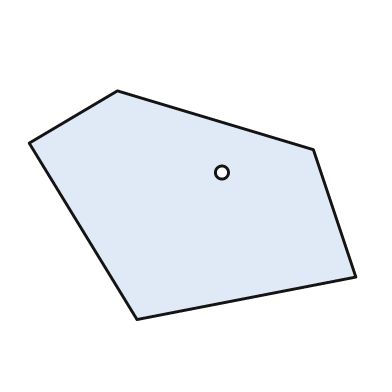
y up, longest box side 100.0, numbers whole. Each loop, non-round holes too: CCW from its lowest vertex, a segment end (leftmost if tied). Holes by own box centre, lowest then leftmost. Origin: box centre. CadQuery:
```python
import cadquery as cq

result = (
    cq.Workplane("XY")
    .moveTo(-17.0, -35.0)
    .lineTo(50.0, -22.0)
    .lineTo(37.0, 17.0)
    .lineTo(-23.0, 35.0)
    .lineTo(-50.0, 19.0)
    .close()
    .moveTo(9.0, 10.0)
    .circle(2.0)
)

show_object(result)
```